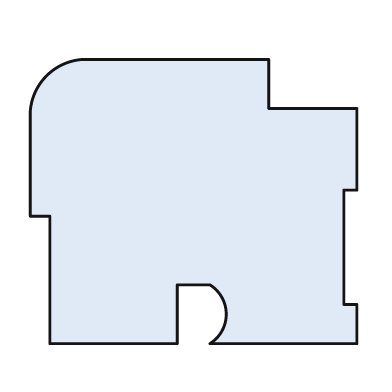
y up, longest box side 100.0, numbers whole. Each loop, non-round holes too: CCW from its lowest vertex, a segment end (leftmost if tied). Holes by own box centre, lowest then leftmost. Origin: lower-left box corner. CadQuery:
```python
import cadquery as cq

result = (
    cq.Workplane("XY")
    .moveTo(6.0, 0.0)
    .lineTo(45.0, 0.0)
    .lineTo(45.0, 18.0)
    .lineTo(55.0, 18.0)
    .threePointArc((60.0, 9.0), (55.0, 0.0))
    .lineTo(100.0, 0.0)
    .lineTo(100.0, 12.0)
    .lineTo(96.0, 12.0)
    .lineTo(96.0, 47.0)
    .lineTo(100.0, 47.0)
    .lineTo(100.0, 72.0)
    .lineTo(73.0, 72.0)
    .lineTo(73.0, 87.0)
    .lineTo(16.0, 87.0)
    .threePointArc((5.0, 82.0), (0.0, 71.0))
    .lineTo(0.0, 39.0)
    .lineTo(6.0, 39.0)
    .close()
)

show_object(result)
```